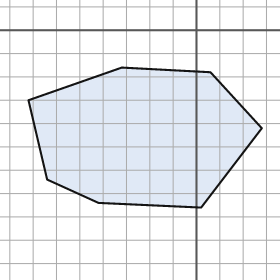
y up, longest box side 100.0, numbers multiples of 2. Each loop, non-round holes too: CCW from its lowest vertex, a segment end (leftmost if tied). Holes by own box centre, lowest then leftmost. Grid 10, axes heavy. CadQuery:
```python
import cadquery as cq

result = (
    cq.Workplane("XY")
    .moveTo(2.0, -76.0)
    .lineTo(28.0, -42.0)
    .lineTo(6.0, -18.0)
    .lineTo(-32.0, -16.0)
    .lineTo(-72.0, -30.0)
    .lineTo(-64.0, -64.0)
    .lineTo(-42.0, -74.0)
    .close()
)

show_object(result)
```